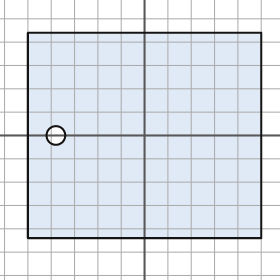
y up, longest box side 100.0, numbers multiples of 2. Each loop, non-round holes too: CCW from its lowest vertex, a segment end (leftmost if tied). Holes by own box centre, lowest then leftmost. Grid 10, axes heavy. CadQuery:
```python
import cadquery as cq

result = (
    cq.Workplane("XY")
    .moveTo(-50.0, -44.0)
    .lineTo(50.0, -44.0)
    .lineTo(50.0, 44.0)
    .lineTo(-50.0, 44.0)
    .close()
    .moveTo(-38.0, 0.0)
    .circle(4.0)
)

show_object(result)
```